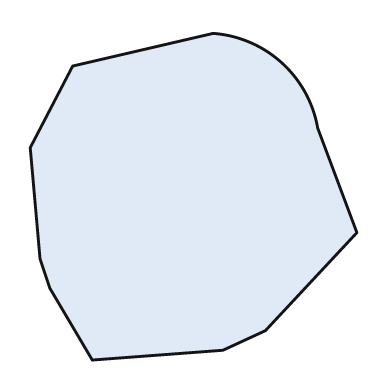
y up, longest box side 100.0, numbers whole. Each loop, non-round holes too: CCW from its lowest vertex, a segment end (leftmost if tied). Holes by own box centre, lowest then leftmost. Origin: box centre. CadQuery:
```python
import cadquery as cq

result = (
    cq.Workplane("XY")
    .moveTo(-31.0, -50.0)
    .lineTo(9.0, -47.0)
    .lineTo(22.0, -41.0)
    .lineTo(50.0, -11.0)
    .lineTo(38.0, 21.0)
    .threePointArc((27.0, 41.0), (6.0, 50.0))
    .lineTo(-37.0, 40.0)
    .lineTo(-50.0, 15.0)
    .lineTo(-47.0, -19.0)
    .lineTo(-44.0, -28.0)
    .close()
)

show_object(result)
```